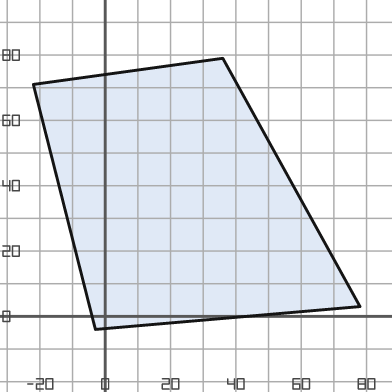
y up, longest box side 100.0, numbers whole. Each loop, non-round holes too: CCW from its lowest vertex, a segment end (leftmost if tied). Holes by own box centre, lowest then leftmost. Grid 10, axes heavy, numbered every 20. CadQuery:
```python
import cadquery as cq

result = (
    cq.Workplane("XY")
    .moveTo(-3.0, -4.0)
    .lineTo(78.0, 3.0)
    .lineTo(36.0, 79.0)
    .lineTo(-22.0, 71.0)
    .close()
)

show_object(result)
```